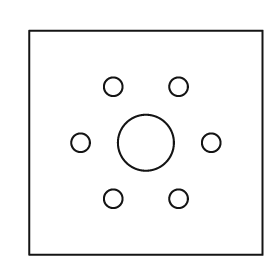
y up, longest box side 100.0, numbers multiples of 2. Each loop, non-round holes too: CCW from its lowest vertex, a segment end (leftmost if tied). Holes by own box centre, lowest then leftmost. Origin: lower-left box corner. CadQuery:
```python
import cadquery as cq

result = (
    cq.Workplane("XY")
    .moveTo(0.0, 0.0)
    .lineTo(100.0, 0.0)
    .lineTo(100.0, 96.0)
    .lineTo(0.0, 96.0)
    .close()
    .moveTo(36.0, 24.0)
    .circle(4.0)
    .moveTo(64.0, 24.0)
    .circle(4.0)
    .moveTo(22.0, 48.0)
    .circle(4.0)
    .moveTo(50.0, 48.0)
    .circle(12.0)
    .moveTo(78.0, 48.0)
    .circle(4.0)
    .moveTo(36.0, 72.0)
    .circle(4.0)
    .moveTo(64.0, 72.0)
    .circle(4.0)
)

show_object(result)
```